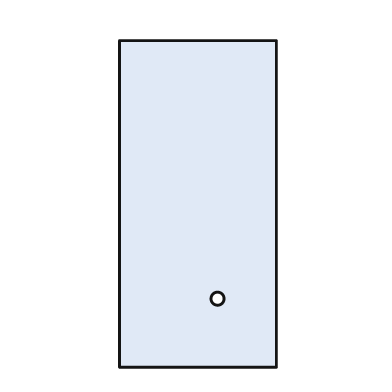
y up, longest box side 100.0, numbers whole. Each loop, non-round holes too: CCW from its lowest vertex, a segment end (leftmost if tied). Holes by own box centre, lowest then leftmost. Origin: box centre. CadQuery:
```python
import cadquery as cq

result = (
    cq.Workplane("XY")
    .moveTo(-24.0, -50.0)
    .lineTo(24.0, -50.0)
    .lineTo(24.0, 50.0)
    .lineTo(-24.0, 50.0)
    .close()
    .moveTo(6.0, -29.0)
    .circle(2.0)
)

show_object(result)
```